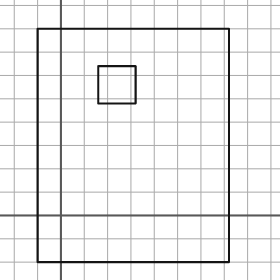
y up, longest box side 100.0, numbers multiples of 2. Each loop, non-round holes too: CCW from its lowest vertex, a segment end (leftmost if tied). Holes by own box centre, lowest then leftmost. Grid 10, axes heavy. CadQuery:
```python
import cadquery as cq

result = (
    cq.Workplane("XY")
    .moveTo(-10.0, -20.0)
    .lineTo(72.0, -20.0)
    .lineTo(72.0, 80.0)
    .lineTo(-10.0, 80.0)
    .close()
    .moveTo(16.0, 48.0)
    .lineTo(32.0, 48.0)
    .lineTo(32.0, 64.0)
    .lineTo(16.0, 64.0)
    .close()
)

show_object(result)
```